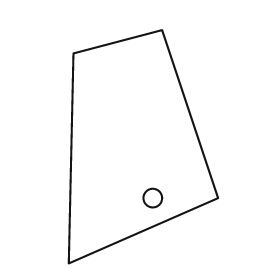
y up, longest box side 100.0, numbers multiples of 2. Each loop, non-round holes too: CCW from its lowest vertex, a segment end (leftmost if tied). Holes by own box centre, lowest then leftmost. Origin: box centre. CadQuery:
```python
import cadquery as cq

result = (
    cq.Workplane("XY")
    .moveTo(-32.0, -50.0)
    .lineTo(32.0, -22.0)
    .lineTo(8.0, 50.0)
    .lineTo(-30.0, 40.0)
    .close()
    .moveTo(4.0, -22.0)
    .circle(4.0)
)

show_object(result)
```